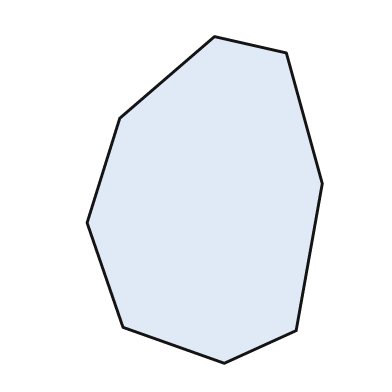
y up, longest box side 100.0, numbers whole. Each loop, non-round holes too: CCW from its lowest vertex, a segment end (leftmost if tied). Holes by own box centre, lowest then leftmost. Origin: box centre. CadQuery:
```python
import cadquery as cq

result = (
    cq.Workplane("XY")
    .moveTo(6.0, -50.0)
    .lineTo(28.0, -40.0)
    .lineTo(36.0, 5.0)
    .lineTo(25.0, 45.0)
    .lineTo(3.0, 50.0)
    .lineTo(-26.0, 25.0)
    .lineTo(-36.0, -7.0)
    .lineTo(-25.0, -39.0)
    .close()
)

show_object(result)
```